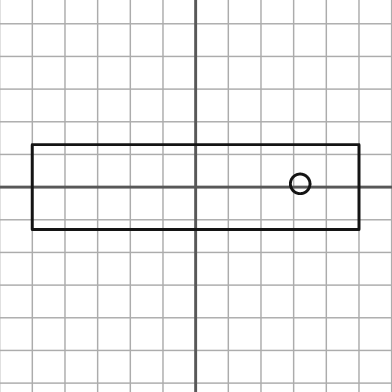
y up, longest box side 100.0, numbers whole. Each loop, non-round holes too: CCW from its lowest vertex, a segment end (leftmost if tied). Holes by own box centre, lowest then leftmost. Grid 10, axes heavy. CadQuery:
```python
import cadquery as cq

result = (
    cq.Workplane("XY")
    .moveTo(-50.0, -13.0)
    .lineTo(50.0, -13.0)
    .lineTo(50.0, 13.0)
    .lineTo(-50.0, 13.0)
    .close()
    .moveTo(32.0, 1.0)
    .circle(3.0)
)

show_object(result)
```